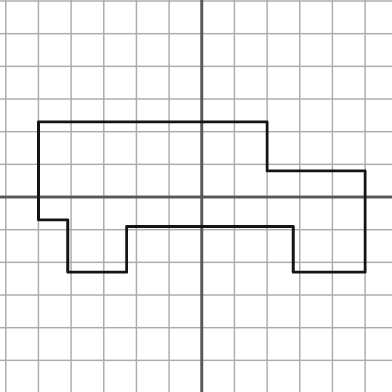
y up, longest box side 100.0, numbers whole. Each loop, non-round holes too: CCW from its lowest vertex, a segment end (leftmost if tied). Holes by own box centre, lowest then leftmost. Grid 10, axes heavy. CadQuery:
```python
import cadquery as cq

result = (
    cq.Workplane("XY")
    .moveTo(-41.0, -23.0)
    .lineTo(-23.0, -23.0)
    .lineTo(-23.0, -9.0)
    .lineTo(28.0, -9.0)
    .lineTo(28.0, -23.0)
    .lineTo(50.0, -23.0)
    .lineTo(50.0, 8.0)
    .lineTo(20.0, 8.0)
    .lineTo(20.0, 23.0)
    .lineTo(-50.0, 23.0)
    .lineTo(-50.0, -7.0)
    .lineTo(-41.0, -7.0)
    .close()
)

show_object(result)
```